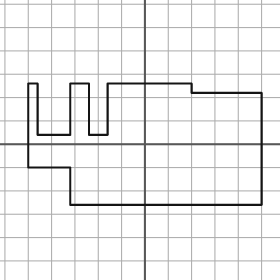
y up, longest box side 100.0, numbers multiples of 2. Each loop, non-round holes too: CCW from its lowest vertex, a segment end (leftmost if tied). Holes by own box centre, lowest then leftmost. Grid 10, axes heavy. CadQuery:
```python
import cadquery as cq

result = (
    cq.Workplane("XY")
    .moveTo(-32.0, -26.0)
    .lineTo(50.0, -26.0)
    .lineTo(50.0, 22.0)
    .lineTo(20.0, 22.0)
    .lineTo(20.0, 26.0)
    .lineTo(-16.0, 26.0)
    .lineTo(-16.0, 4.0)
    .lineTo(-24.0, 4.0)
    .lineTo(-24.0, 26.0)
    .lineTo(-32.0, 26.0)
    .lineTo(-32.0, 4.0)
    .lineTo(-46.0, 4.0)
    .lineTo(-46.0, 26.0)
    .lineTo(-50.0, 26.0)
    .lineTo(-50.0, -10.0)
    .lineTo(-32.0, -10.0)
    .close()
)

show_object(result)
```